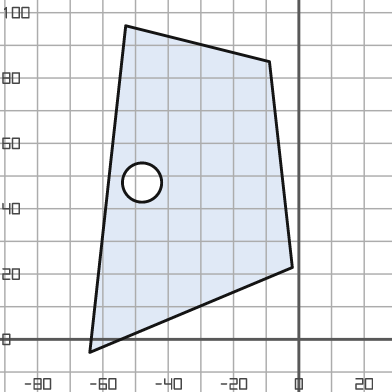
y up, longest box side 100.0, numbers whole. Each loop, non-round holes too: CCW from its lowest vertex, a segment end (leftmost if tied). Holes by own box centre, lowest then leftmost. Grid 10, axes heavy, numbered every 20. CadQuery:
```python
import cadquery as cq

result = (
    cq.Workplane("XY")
    .moveTo(-64.0, -4.0)
    .lineTo(-2.0, 22.0)
    .lineTo(-9.0, 85.0)
    .lineTo(-53.0, 96.0)
    .close()
    .moveTo(-48.0, 48.0)
    .circle(6.0)
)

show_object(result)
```